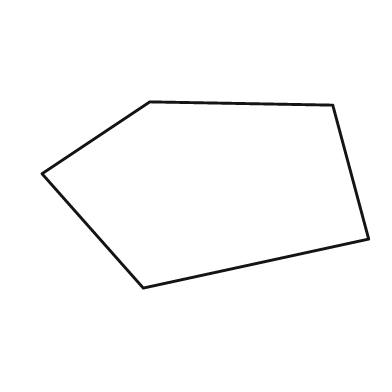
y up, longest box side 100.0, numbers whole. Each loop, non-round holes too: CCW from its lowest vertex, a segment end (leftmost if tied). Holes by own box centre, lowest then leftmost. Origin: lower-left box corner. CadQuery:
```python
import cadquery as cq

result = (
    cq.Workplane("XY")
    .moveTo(31.0, 0.0)
    .lineTo(100.0, 15.0)
    .lineTo(89.0, 56.0)
    .lineTo(33.0, 57.0)
    .lineTo(0.0, 35.0)
    .close()
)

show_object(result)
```